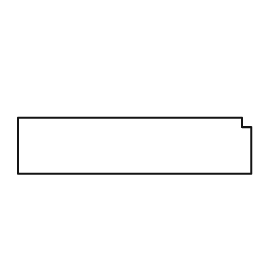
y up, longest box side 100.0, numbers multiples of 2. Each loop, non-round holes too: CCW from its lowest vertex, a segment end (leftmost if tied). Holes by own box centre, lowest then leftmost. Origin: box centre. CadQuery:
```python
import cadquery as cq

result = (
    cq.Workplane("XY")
    .moveTo(-50.0, -12.0)
    .lineTo(50.0, -12.0)
    .lineTo(50.0, 8.0)
    .lineTo(46.0, 8.0)
    .lineTo(46.0, 12.0)
    .lineTo(-50.0, 12.0)
    .close()
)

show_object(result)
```